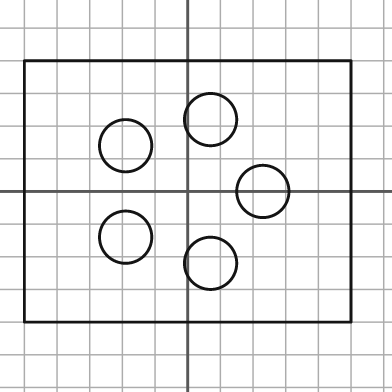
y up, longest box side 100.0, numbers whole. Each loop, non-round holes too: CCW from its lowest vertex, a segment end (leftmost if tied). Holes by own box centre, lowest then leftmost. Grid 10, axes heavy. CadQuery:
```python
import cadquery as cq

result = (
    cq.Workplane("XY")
    .moveTo(-50.0, -40.0)
    .lineTo(50.0, -40.0)
    .lineTo(50.0, 40.0)
    .lineTo(-50.0, 40.0)
    .close()
    .moveTo(7.0, -22.0)
    .circle(8.0)
    .moveTo(-19.0, -14.0)
    .circle(8.0)
    .moveTo(23.0, 0.0)
    .circle(8.0)
    .moveTo(-19.0, 14.0)
    .circle(8.0)
    .moveTo(7.0, 22.0)
    .circle(8.0)
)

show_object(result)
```